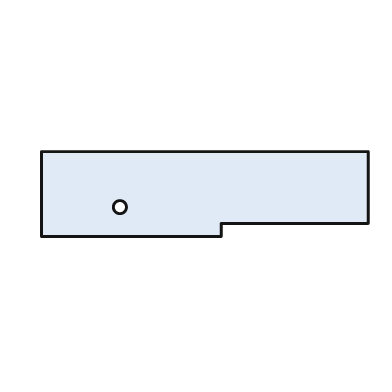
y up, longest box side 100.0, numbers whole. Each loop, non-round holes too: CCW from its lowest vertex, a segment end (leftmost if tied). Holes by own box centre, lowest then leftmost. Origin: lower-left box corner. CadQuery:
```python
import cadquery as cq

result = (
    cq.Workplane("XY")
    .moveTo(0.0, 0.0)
    .lineTo(55.0, 0.0)
    .lineTo(55.0, 4.0)
    .lineTo(100.0, 4.0)
    .lineTo(100.0, 26.0)
    .lineTo(0.0, 26.0)
    .close()
    .moveTo(24.0, 9.0)
    .circle(2.0)
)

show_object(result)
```